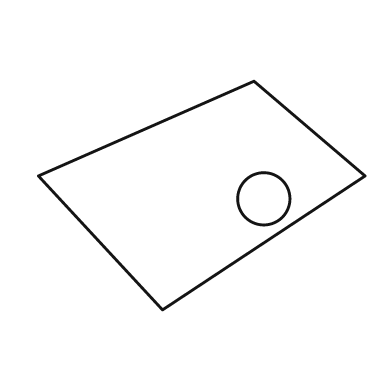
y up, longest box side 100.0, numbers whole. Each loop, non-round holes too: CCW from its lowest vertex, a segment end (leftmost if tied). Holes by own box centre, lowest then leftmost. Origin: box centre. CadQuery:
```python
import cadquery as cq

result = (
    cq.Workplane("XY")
    .moveTo(-12.0, -35.0)
    .lineTo(50.0, 6.0)
    .lineTo(16.0, 35.0)
    .lineTo(-50.0, 6.0)
    .close()
    .moveTo(19.0, -1.0)
    .circle(8.0)
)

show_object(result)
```